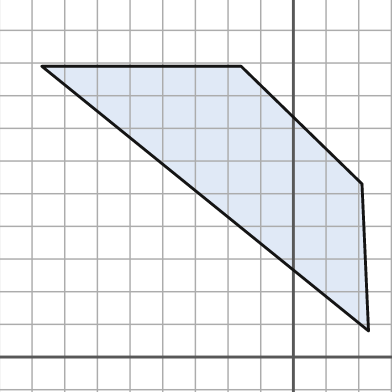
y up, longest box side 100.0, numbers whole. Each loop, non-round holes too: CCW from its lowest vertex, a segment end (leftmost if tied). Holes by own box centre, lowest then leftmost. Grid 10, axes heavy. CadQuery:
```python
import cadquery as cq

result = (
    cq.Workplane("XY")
    .moveTo(23.0, 8.0)
    .lineTo(21.0, 53.0)
    .lineTo(-16.0, 89.0)
    .lineTo(-77.0, 89.0)
    .close()
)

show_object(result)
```